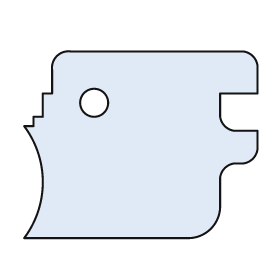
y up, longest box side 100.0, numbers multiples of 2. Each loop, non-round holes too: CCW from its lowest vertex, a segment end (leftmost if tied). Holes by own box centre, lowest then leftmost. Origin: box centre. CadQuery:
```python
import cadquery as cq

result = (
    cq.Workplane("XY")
    .moveTo(-50.0, -40.0)
    .lineTo(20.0, -40.0)
    .threePointArc((30.0, -36.0), (34.0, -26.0))
    .lineTo(34.0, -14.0)
    .threePointArc((36.0, -10.0), (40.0, -8.0))
    .lineTo(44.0, -8.0)
    .threePointArc((48.0, -6.0), (50.0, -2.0))
    .lineTo(50.0, 6.0)
    .lineTo(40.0, 6.0)
    .threePointArc((36.0, 8.0), (34.0, 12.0))
    .lineTo(34.0, 22.0)
    .lineTo(50.0, 22.0)
    .lineTo(50.0, 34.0)
    .threePointArc((48.0, 38.0), (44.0, 40.0))
    .lineTo(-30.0, 40.0)
    .threePointArc((-36.0, 38.0), (-38.0, 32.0))
    .lineTo(-38.0, 22.0)
    .lineTo(-42.0, 22.0)
    .lineTo(-42.0, 12.0)
    .lineTo(-46.0, 12.0)
    .lineTo(-46.0, 8.0)
    .lineTo(-50.0, 8.0)
    .threePointArc((-42.0, -16.0), (-50.0, -40.0))
    .close()
    .moveTo(-20.0, 18.0)
    .circle(6.0)
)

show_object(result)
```